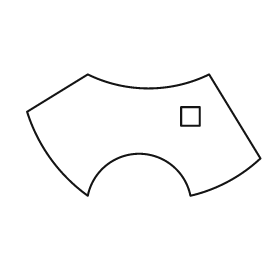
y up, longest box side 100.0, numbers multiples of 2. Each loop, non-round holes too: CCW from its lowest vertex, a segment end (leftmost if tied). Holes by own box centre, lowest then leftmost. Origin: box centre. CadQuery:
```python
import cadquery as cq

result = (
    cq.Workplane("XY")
    .moveTo(-24.0, -26.0)
    .threePointArc((-2.0, -8.0), (20.0, -26.0))
    .threePointArc((36.0, -20.0), (50.0, -10.0))
    .lineTo(28.0, 26.0)
    .threePointArc((2.0, 20.0), (-24.0, 26.0))
    .lineTo(-50.0, 10.0)
    .threePointArc((-40.0, -10.0), (-24.0, -26.0))
    .close()
    .moveTo(16.0, 4.0)
    .lineTo(24.0, 4.0)
    .lineTo(24.0, 12.0)
    .lineTo(16.0, 12.0)
    .close()
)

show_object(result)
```